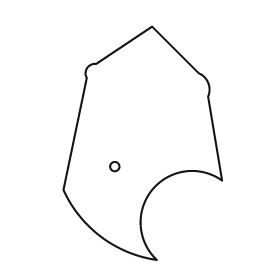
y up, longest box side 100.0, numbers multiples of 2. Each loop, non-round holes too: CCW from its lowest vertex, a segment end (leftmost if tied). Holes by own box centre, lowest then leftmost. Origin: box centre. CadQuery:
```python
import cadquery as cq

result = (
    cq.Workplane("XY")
    .moveTo(6.0, -50.0)
    .threePointArc((4.0, -20.0), (34.0, -16.0))
    .lineTo(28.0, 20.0)
    .threePointArc((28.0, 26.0), (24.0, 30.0))
    .lineTo(4.0, 50.0)
    .lineTo(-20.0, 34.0)
    .threePointArc((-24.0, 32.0), (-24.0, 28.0))
    .lineTo(-34.0, -20.0)
    .threePointArc((-18.0, -40.0), (6.0, -50.0))
    .close()
    .moveTo(-12.0, -10.0)
    .circle(2.0)
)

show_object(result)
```